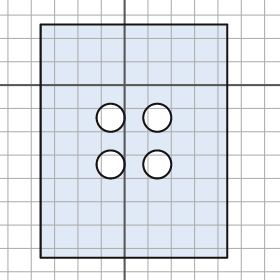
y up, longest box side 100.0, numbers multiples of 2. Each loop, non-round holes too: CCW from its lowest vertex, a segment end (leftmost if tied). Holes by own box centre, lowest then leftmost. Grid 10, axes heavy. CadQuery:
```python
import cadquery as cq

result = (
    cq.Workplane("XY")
    .moveTo(-36.0, -74.0)
    .lineTo(44.0, -74.0)
    .lineTo(44.0, 26.0)
    .lineTo(-36.0, 26.0)
    .close()
    .moveTo(-6.0, -34.0)
    .circle(6.0)
    .moveTo(14.0, -34.0)
    .circle(6.0)
    .moveTo(-6.0, -14.0)
    .circle(6.0)
    .moveTo(14.0, -14.0)
    .circle(6.0)
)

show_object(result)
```